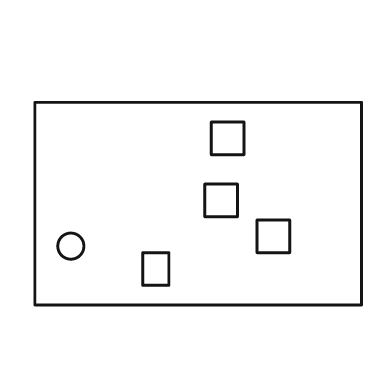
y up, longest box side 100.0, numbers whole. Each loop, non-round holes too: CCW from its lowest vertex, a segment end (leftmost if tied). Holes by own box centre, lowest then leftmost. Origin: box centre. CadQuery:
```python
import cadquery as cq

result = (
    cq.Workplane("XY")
    .moveTo(-50.0, -31.0)
    .lineTo(50.0, -31.0)
    .lineTo(50.0, 31.0)
    .lineTo(-50.0, 31.0)
    .close()
    .moveTo(-17.0, -25.0)
    .lineTo(-9.0, -25.0)
    .lineTo(-9.0, -15.0)
    .lineTo(-17.0, -15.0)
    .close()
    .moveTo(-39.0, -13.0)
    .circle(4.0)
    .moveTo(18.0, -15.0)
    .lineTo(28.0, -15.0)
    .lineTo(28.0, -5.0)
    .lineTo(18.0, -5.0)
    .close()
    .moveTo(2.0, -4.0)
    .lineTo(12.0, -4.0)
    .lineTo(12.0, 6.0)
    .lineTo(2.0, 6.0)
    .close()
    .moveTo(4.0, 15.0)
    .lineTo(14.0, 15.0)
    .lineTo(14.0, 25.0)
    .lineTo(4.0, 25.0)
    .close()
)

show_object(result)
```